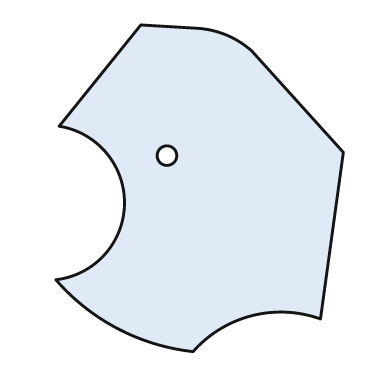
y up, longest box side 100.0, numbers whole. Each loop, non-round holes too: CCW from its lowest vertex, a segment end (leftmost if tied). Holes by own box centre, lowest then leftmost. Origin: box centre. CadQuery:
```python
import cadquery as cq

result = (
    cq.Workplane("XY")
    .moveTo(-2.0, -50.0)
    .threePointArc((16.0, -39.0), (37.0, -40.0))
    .lineTo(44.0, 11.0)
    .lineTo(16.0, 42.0)
    .threePointArc((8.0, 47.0), (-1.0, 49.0))
    .lineTo(-18.0, 50.0)
    .lineTo(-43.0, 19.0)
    .threePointArc((-23.0, -5.0), (-44.0, -28.0))
    .threePointArc((-25.0, -43.0), (-2.0, -50.0))
    .close()
    .moveTo(-10.0, 10.0)
    .circle(3.0)
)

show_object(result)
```